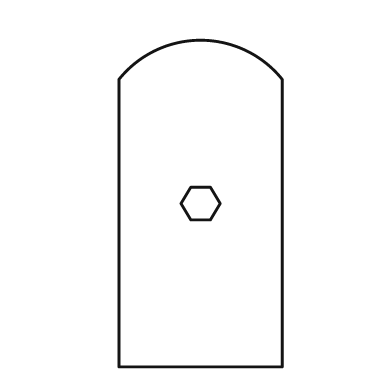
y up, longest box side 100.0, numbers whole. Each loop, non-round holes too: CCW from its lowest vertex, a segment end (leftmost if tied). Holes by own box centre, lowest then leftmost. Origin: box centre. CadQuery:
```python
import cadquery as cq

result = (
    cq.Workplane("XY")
    .moveTo(-25.0, -50.0)
    .lineTo(25.0, -50.0)
    .lineTo(25.0, 38.0)
    .threePointArc((0.0, 50.0), (-25.0, 38.0))
    .close()
    .moveTo(-3.0, -5.0)
    .lineTo(3.0, -5.0)
    .lineTo(6.0, 0.0)
    .lineTo(3.0, 5.0)
    .lineTo(-3.0, 5.0)
    .lineTo(-6.0, 0.0)
    .close()
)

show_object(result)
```